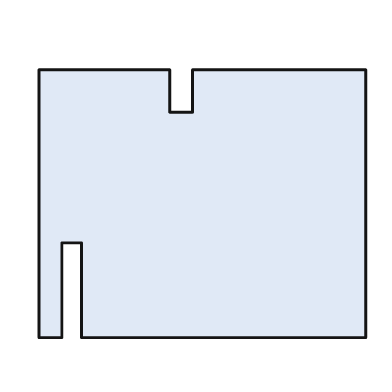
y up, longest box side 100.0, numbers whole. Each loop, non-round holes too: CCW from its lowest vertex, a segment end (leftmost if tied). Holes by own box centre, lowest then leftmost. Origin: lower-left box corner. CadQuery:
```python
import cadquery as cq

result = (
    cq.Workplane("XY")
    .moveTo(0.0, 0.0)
    .lineTo(7.0, 0.0)
    .lineTo(7.0, 29.0)
    .lineTo(13.0, 29.0)
    .lineTo(13.0, 0.0)
    .lineTo(100.0, 0.0)
    .lineTo(100.0, 82.0)
    .lineTo(47.0, 82.0)
    .lineTo(47.0, 69.0)
    .lineTo(40.0, 69.0)
    .lineTo(40.0, 82.0)
    .lineTo(0.0, 82.0)
    .close()
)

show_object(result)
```